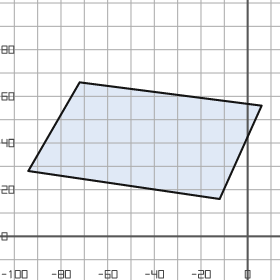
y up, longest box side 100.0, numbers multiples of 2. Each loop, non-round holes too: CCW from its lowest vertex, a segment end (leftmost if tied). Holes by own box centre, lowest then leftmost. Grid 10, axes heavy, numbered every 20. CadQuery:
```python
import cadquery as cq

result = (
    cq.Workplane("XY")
    .moveTo(-12.0, 16.0)
    .lineTo(6.0, 56.0)
    .lineTo(-72.0, 66.0)
    .lineTo(-94.0, 28.0)
    .close()
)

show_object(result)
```